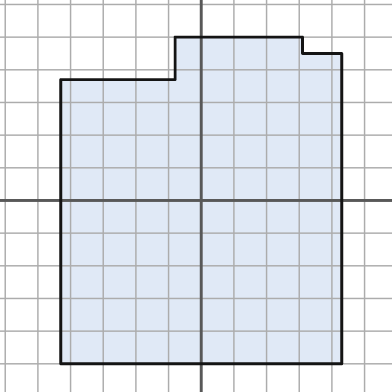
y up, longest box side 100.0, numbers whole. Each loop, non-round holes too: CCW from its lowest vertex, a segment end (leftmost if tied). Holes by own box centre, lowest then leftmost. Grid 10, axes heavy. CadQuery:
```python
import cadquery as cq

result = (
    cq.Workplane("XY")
    .moveTo(-43.0, -50.0)
    .lineTo(43.0, -50.0)
    .lineTo(43.0, 45.0)
    .lineTo(31.0, 45.0)
    .lineTo(31.0, 50.0)
    .lineTo(-8.0, 50.0)
    .lineTo(-8.0, 37.0)
    .lineTo(-43.0, 37.0)
    .close()
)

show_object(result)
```